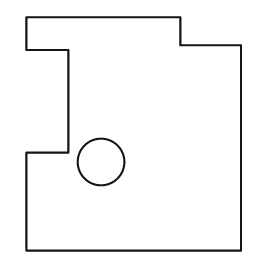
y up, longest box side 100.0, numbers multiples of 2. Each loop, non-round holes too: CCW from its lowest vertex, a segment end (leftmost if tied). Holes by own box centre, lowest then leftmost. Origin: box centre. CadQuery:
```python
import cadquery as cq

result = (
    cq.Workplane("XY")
    .moveTo(-46.0, -50.0)
    .lineTo(46.0, -50.0)
    .lineTo(46.0, 38.0)
    .lineTo(20.0, 38.0)
    .lineTo(20.0, 50.0)
    .lineTo(-46.0, 50.0)
    .lineTo(-46.0, 36.0)
    .lineTo(-28.0, 36.0)
    .lineTo(-28.0, -8.0)
    .lineTo(-46.0, -8.0)
    .close()
    .moveTo(-14.0, -12.0)
    .circle(10.0)
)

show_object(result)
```